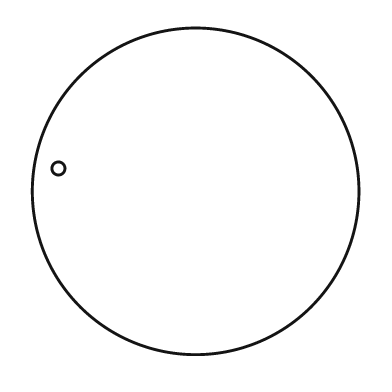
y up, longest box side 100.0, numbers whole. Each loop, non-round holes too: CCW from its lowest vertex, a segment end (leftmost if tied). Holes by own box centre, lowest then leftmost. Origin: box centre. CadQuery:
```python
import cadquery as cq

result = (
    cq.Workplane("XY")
    .moveTo(0.0, 0.0)
    .circle(50.0)
    .moveTo(-42.0, 7.0)
    .circle(2.0)
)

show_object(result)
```